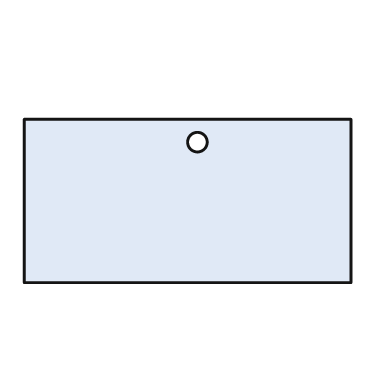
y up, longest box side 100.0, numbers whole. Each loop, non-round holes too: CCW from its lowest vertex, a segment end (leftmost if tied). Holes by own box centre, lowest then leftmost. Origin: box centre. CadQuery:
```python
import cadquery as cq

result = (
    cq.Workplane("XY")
    .moveTo(-50.0, -25.0)
    .lineTo(50.0, -25.0)
    .lineTo(50.0, 25.0)
    .lineTo(-50.0, 25.0)
    .close()
    .moveTo(3.0, 18.0)
    .circle(3.0)
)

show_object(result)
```